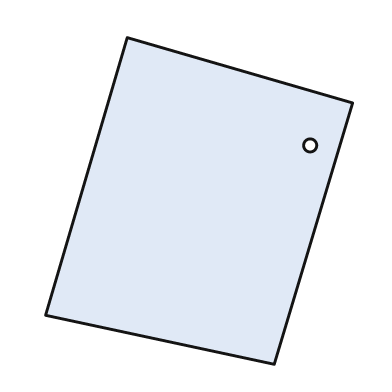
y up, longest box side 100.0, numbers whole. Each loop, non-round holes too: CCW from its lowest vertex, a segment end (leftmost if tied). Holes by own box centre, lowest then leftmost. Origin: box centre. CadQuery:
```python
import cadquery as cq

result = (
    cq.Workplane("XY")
    .moveTo(23.0, -50.0)
    .lineTo(47.0, 30.0)
    .lineTo(-22.0, 50.0)
    .lineTo(-47.0, -35.0)
    .close()
    .moveTo(34.0, 17.0)
    .circle(2.0)
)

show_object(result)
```